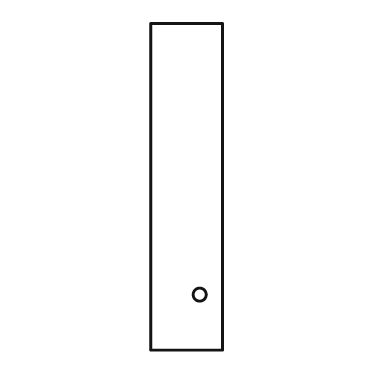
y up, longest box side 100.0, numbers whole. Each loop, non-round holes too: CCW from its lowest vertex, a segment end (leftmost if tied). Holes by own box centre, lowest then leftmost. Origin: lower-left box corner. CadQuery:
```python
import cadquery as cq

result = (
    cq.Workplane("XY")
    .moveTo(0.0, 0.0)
    .lineTo(22.0, 0.0)
    .lineTo(22.0, 100.0)
    .lineTo(0.0, 100.0)
    .close()
    .moveTo(15.0, 17.0)
    .circle(2.0)
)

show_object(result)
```